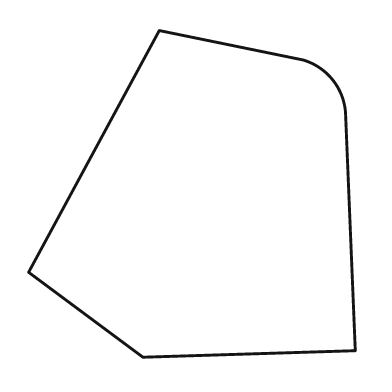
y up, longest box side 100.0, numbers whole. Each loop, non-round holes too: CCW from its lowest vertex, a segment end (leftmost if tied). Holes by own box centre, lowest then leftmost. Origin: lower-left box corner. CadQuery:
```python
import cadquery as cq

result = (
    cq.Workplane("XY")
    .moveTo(35.0, 0.0)
    .lineTo(100.0, 2.0)
    .lineTo(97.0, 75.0)
    .threePointArc((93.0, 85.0), (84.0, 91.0))
    .lineTo(40.0, 100.0)
    .lineTo(0.0, 26.0)
    .close()
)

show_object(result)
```